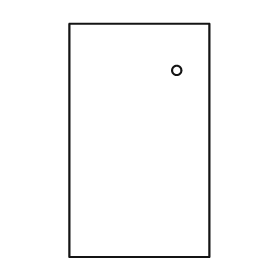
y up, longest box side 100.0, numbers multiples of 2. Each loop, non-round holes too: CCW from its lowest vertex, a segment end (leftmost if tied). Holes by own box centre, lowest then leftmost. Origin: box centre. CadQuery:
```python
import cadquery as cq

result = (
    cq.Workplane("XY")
    .moveTo(-30.0, -50.0)
    .lineTo(30.0, -50.0)
    .lineTo(30.0, 50.0)
    .lineTo(-30.0, 50.0)
    .close()
    .moveTo(16.0, 30.0)
    .circle(2.0)
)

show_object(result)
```